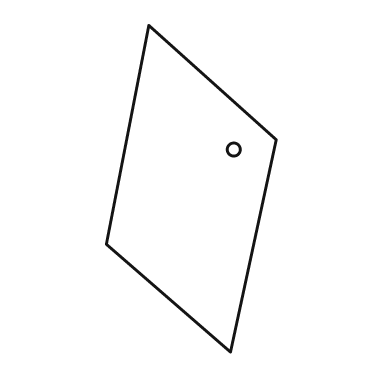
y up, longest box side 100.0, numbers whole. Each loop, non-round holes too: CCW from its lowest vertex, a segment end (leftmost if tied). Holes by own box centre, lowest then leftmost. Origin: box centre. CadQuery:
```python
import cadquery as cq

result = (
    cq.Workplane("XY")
    .moveTo(12.0, -50.0)
    .lineTo(26.0, 15.0)
    .lineTo(-13.0, 50.0)
    .lineTo(-26.0, -17.0)
    .close()
    .moveTo(13.0, 12.0)
    .circle(2.0)
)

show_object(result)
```